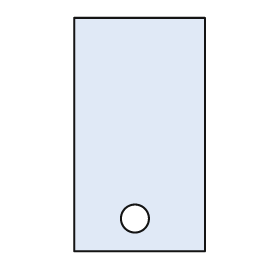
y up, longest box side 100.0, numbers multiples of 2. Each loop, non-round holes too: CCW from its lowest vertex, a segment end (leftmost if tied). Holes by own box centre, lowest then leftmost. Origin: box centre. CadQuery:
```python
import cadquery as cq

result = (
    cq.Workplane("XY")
    .moveTo(-28.0, -50.0)
    .lineTo(28.0, -50.0)
    .lineTo(28.0, 50.0)
    .lineTo(-28.0, 50.0)
    .close()
    .moveTo(-2.0, -36.0)
    .circle(6.0)
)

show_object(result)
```